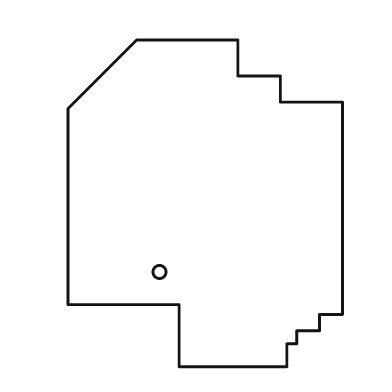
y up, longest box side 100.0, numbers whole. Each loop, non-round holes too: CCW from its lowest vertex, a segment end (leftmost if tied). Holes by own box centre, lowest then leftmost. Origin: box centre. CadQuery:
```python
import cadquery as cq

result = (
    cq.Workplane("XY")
    .moveTo(-8.0, -50.0)
    .lineTo(25.0, -50.0)
    .lineTo(25.0, -43.0)
    .lineTo(28.0, -43.0)
    .lineTo(28.0, -39.0)
    .lineTo(35.0, -39.0)
    .lineTo(35.0, -34.0)
    .lineTo(42.0, -34.0)
    .lineTo(42.0, 31.0)
    .lineTo(23.0, 31.0)
    .lineTo(23.0, 39.0)
    .lineTo(10.0, 39.0)
    .lineTo(10.0, 50.0)
    .lineTo(-21.0, 50.0)
    .lineTo(-42.0, 29.0)
    .lineTo(-42.0, -31.0)
    .lineTo(-8.0, -31.0)
    .close()
    .moveTo(-14.0, -21.0)
    .circle(2.0)
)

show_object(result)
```